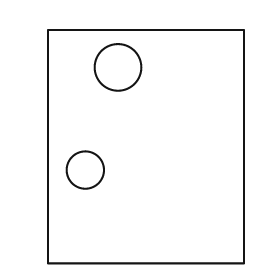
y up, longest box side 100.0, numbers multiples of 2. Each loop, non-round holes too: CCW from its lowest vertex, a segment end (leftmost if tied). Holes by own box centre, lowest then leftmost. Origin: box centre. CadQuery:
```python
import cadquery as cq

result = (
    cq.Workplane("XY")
    .moveTo(-42.0, -50.0)
    .lineTo(42.0, -50.0)
    .lineTo(42.0, 50.0)
    .lineTo(-42.0, 50.0)
    .close()
    .moveTo(-26.0, -10.0)
    .circle(8.0)
    .moveTo(-12.0, 34.0)
    .circle(10.0)
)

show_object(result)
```